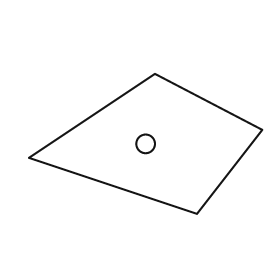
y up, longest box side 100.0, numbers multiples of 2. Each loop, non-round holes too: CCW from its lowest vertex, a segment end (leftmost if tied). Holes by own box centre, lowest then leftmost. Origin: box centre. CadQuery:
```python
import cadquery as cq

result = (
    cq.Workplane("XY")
    .moveTo(22.0, -30.0)
    .lineTo(50.0, 6.0)
    .lineTo(4.0, 30.0)
    .lineTo(-50.0, -6.0)
    .close()
    .moveTo(0.0, 0.0)
    .circle(4.0)
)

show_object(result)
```